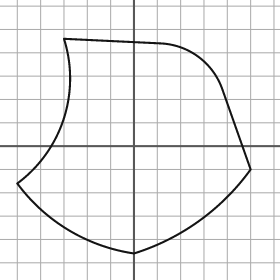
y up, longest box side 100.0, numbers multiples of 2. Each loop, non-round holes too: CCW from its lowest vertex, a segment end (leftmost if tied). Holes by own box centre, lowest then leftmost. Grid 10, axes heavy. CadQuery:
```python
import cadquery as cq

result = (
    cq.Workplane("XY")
    .moveTo(0.0, -46.0)
    .threePointArc((28.0, -32.0), (50.0, -10.0))
    .lineTo(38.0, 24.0)
    .threePointArc((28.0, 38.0), (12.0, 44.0))
    .lineTo(-30.0, 46.0)
    .threePointArc((-30.0, 12.0), (-50.0, -16.0))
    .threePointArc((-28.0, -36.0), (0.0, -46.0))
    .close()
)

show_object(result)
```